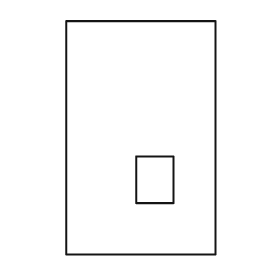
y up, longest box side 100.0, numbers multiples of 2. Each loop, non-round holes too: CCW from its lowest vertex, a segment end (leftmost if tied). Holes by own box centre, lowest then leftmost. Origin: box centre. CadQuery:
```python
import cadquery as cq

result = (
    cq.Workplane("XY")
    .moveTo(-32.0, -50.0)
    .lineTo(32.0, -50.0)
    .lineTo(32.0, 50.0)
    .lineTo(-32.0, 50.0)
    .close()
    .moveTo(-2.0, -28.0)
    .lineTo(14.0, -28.0)
    .lineTo(14.0, -8.0)
    .lineTo(-2.0, -8.0)
    .close()
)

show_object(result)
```